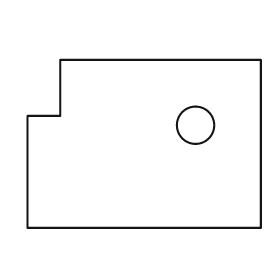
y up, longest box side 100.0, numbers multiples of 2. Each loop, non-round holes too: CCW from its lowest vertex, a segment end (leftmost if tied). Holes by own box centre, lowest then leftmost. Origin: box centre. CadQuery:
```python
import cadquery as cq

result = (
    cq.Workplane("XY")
    .moveTo(-50.0, -36.0)
    .lineTo(50.0, -36.0)
    .lineTo(50.0, 36.0)
    .lineTo(-36.0, 36.0)
    .lineTo(-36.0, 12.0)
    .lineTo(-50.0, 12.0)
    .close()
    .moveTo(22.0, 8.0)
    .circle(8.0)
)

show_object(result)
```